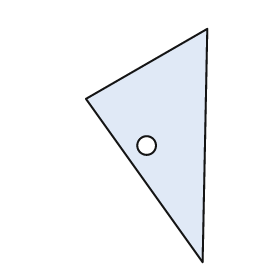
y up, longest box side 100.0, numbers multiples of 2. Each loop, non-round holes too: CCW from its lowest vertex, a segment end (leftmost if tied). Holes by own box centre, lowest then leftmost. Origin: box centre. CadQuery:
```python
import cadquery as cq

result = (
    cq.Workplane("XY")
    .moveTo(24.0, -50.0)
    .lineTo(26.0, 50.0)
    .lineTo(-26.0, 20.0)
    .close()
    .moveTo(0.0, 0.0)
    .circle(4.0)
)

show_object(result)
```